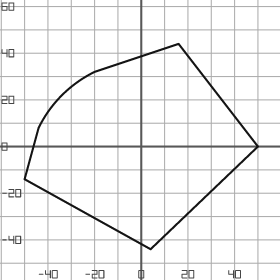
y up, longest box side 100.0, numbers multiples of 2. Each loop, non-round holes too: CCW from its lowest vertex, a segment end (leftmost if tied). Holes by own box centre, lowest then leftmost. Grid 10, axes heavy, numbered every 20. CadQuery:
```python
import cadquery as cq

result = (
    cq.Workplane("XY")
    .moveTo(4.0, -44.0)
    .lineTo(50.0, 0.0)
    .lineTo(16.0, 44.0)
    .lineTo(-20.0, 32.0)
    .threePointArc((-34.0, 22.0), (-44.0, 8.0))
    .lineTo(-50.0, -14.0)
    .close()
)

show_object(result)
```